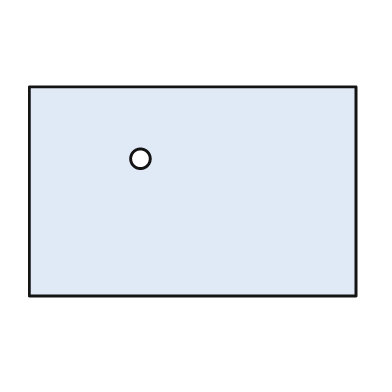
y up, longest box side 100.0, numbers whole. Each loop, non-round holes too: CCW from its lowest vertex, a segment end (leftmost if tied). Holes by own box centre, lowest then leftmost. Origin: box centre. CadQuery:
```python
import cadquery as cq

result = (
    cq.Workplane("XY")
    .moveTo(-50.0, -32.0)
    .lineTo(50.0, -32.0)
    .lineTo(50.0, 32.0)
    .lineTo(-50.0, 32.0)
    .close()
    .moveTo(-16.0, 10.0)
    .circle(3.0)
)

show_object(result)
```